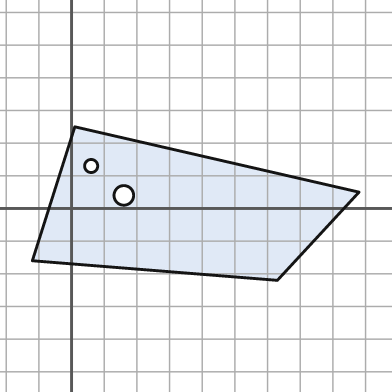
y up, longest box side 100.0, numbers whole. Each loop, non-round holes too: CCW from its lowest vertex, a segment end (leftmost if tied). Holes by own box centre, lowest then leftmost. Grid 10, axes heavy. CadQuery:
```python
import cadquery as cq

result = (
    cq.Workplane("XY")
    .moveTo(63.0, -22.0)
    .lineTo(88.0, 5.0)
    .lineTo(1.0, 25.0)
    .lineTo(-12.0, -16.0)
    .close()
    .moveTo(16.0, 4.0)
    .circle(3.0)
    .moveTo(6.0, 13.0)
    .circle(2.0)
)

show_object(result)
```